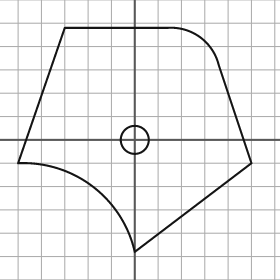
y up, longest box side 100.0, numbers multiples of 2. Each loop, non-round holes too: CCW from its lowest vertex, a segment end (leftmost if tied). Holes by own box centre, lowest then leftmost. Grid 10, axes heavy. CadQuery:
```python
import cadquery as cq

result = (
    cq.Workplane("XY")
    .moveTo(0.0, -48.0)
    .lineTo(50.0, -10.0)
    .lineTo(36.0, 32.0)
    .threePointArc((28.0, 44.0), (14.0, 48.0))
    .lineTo(-30.0, 48.0)
    .lineTo(-50.0, -10.0)
    .threePointArc((-18.0, -20.0), (0.0, -48.0))
    .close()
    .moveTo(0.0, 0.0)
    .circle(6.0)
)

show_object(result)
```